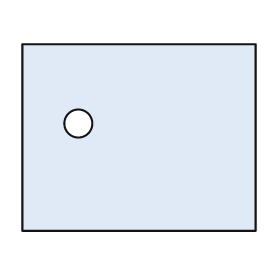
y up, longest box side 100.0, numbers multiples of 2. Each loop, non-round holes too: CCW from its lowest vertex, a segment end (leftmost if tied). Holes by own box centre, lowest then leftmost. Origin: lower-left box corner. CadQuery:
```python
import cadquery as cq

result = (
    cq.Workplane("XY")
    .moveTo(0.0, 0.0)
    .lineTo(100.0, 0.0)
    .lineTo(100.0, 80.0)
    .lineTo(0.0, 80.0)
    .close()
    .moveTo(24.0, 46.0)
    .circle(6.0)
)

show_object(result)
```